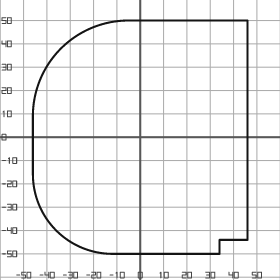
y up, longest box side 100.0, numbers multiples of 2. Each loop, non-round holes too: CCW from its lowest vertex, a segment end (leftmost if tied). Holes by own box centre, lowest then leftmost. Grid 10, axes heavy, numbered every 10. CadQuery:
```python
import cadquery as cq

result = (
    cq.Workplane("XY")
    .moveTo(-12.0, -50.0)
    .lineTo(34.0, -50.0)
    .lineTo(34.0, -44.0)
    .lineTo(46.0, -44.0)
    .lineTo(46.0, 50.0)
    .lineTo(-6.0, 50.0)
    .threePointArc((-34.0, 38.0), (-46.0, 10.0))
    .lineTo(-46.0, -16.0)
    .threePointArc((-36.0, -40.0), (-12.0, -50.0))
    .close()
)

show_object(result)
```